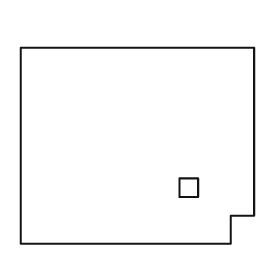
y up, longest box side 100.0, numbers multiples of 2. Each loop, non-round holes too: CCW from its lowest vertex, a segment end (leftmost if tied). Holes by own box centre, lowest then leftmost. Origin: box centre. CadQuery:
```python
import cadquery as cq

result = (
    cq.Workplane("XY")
    .moveTo(-50.0, -42.0)
    .lineTo(40.0, -42.0)
    .lineTo(40.0, -30.0)
    .lineTo(50.0, -30.0)
    .lineTo(50.0, 42.0)
    .lineTo(-50.0, 42.0)
    .close()
    .moveTo(18.0, -22.0)
    .lineTo(26.0, -22.0)
    .lineTo(26.0, -14.0)
    .lineTo(18.0, -14.0)
    .close()
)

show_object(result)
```